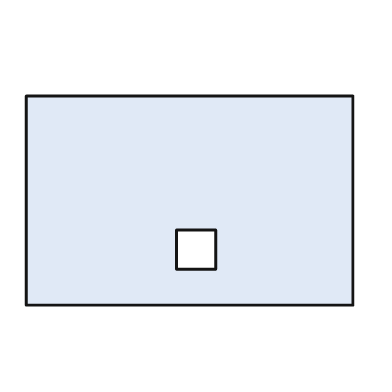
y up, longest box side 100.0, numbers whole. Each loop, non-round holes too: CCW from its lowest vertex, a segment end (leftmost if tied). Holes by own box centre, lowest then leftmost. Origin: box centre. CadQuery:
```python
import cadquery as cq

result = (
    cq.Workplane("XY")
    .moveTo(-50.0, -32.0)
    .lineTo(50.0, -32.0)
    .lineTo(50.0, 32.0)
    .lineTo(-50.0, 32.0)
    .close()
    .moveTo(-4.0, -21.0)
    .lineTo(8.0, -21.0)
    .lineTo(8.0, -9.0)
    .lineTo(-4.0, -9.0)
    .close()
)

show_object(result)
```